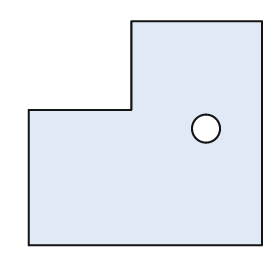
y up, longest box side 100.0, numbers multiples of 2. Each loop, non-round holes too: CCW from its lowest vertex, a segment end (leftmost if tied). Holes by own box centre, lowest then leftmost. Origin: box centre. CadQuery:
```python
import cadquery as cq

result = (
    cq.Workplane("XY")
    .moveTo(-50.0, -48.0)
    .lineTo(50.0, -48.0)
    .lineTo(50.0, 48.0)
    .lineTo(-6.0, 48.0)
    .lineTo(-6.0, 10.0)
    .lineTo(-50.0, 10.0)
    .close()
    .moveTo(26.0, 2.0)
    .circle(6.0)
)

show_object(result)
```